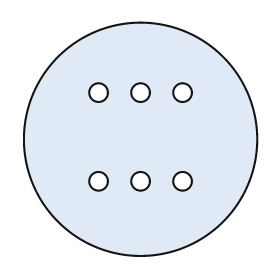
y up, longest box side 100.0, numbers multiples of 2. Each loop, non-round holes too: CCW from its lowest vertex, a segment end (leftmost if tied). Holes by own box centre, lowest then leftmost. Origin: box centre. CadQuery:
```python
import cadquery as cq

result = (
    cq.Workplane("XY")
    .moveTo(0.0, 0.0)
    .circle(50.0)
    .moveTo(-18.0, -18.0)
    .circle(4.0)
    .moveTo(0.0, -18.0)
    .circle(4.0)
    .moveTo(18.0, -18.0)
    .circle(4.0)
    .moveTo(-18.0, 20.0)
    .circle(4.0)
    .moveTo(0.0, 20.0)
    .circle(4.0)
    .moveTo(18.0, 20.0)
    .circle(4.0)
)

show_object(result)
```